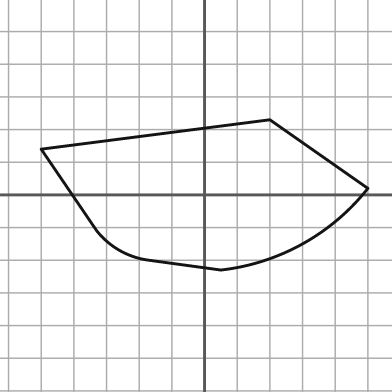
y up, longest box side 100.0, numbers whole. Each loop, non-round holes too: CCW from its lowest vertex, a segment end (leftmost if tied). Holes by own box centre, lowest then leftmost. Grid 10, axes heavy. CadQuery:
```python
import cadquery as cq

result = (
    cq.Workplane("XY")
    .moveTo(5.0, -23.0)
    .threePointArc((30.0, -15.0), (50.0, 2.0))
    .lineTo(20.0, 23.0)
    .lineTo(-50.0, 14.0)
    .lineTo(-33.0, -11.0)
    .threePointArc((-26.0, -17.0), (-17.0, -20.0))
    .close()
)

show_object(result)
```